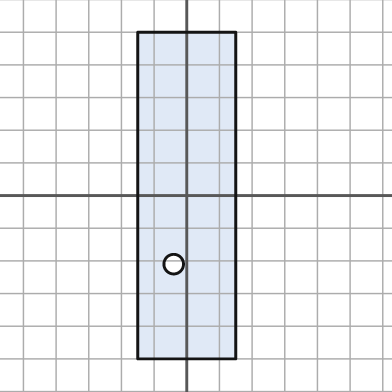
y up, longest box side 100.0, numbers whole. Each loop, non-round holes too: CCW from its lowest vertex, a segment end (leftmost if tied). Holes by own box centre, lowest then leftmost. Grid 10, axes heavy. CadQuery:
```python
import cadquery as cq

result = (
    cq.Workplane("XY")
    .moveTo(-15.0, -50.0)
    .lineTo(15.0, -50.0)
    .lineTo(15.0, 50.0)
    .lineTo(-15.0, 50.0)
    .close()
    .moveTo(-4.0, -21.0)
    .circle(3.0)
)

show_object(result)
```